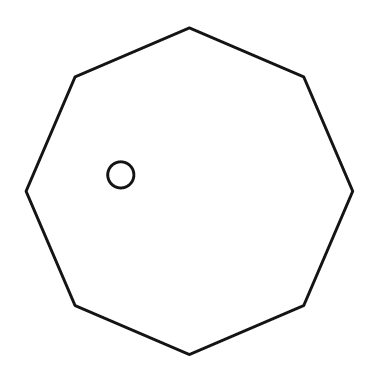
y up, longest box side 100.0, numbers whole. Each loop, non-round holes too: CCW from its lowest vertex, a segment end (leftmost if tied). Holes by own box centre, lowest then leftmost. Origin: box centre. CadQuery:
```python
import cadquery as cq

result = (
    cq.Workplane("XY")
    .moveTo(0.0, -50.0)
    .lineTo(35.0, -35.0)
    .lineTo(50.0, 0.0)
    .lineTo(35.0, 35.0)
    .lineTo(0.0, 50.0)
    .lineTo(-35.0, 35.0)
    .lineTo(-50.0, 0.0)
    .lineTo(-35.0, -35.0)
    .close()
    .moveTo(-21.0, 5.0)
    .circle(4.0)
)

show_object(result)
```